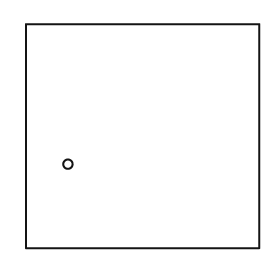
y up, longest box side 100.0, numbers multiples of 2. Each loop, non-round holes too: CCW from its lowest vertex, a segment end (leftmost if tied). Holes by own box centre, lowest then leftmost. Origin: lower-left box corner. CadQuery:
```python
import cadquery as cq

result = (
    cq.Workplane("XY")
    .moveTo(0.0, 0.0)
    .lineTo(100.0, 0.0)
    .lineTo(100.0, 96.0)
    .lineTo(0.0, 96.0)
    .close()
    .moveTo(18.0, 36.0)
    .circle(2.0)
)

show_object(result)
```